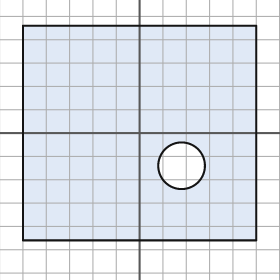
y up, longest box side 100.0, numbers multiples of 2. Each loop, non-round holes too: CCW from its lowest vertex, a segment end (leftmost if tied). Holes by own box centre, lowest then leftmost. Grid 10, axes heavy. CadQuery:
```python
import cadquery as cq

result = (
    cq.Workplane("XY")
    .moveTo(-50.0, -46.0)
    .lineTo(50.0, -46.0)
    .lineTo(50.0, 46.0)
    .lineTo(-50.0, 46.0)
    .close()
    .moveTo(18.0, -14.0)
    .circle(10.0)
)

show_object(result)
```